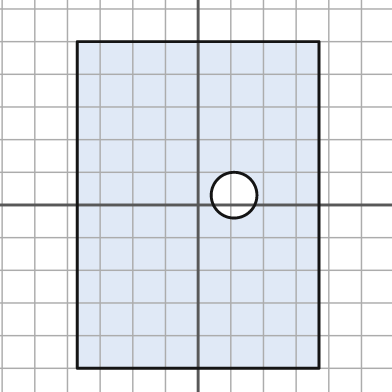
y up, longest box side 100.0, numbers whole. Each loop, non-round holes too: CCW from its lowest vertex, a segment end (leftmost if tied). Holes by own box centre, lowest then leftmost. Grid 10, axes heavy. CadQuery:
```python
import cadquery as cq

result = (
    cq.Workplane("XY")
    .moveTo(-37.0, -50.0)
    .lineTo(37.0, -50.0)
    .lineTo(37.0, 50.0)
    .lineTo(-37.0, 50.0)
    .close()
    .moveTo(11.0, 3.0)
    .circle(7.0)
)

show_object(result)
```